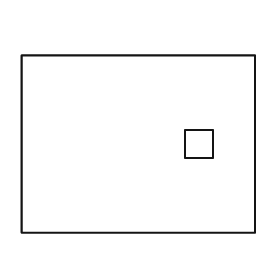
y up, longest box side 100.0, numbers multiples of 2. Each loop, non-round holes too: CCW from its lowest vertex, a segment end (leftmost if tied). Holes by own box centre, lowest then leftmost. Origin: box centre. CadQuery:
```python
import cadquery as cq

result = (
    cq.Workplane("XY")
    .moveTo(-50.0, -38.0)
    .lineTo(50.0, -38.0)
    .lineTo(50.0, 38.0)
    .lineTo(-50.0, 38.0)
    .close()
    .moveTo(20.0, -6.0)
    .lineTo(32.0, -6.0)
    .lineTo(32.0, 6.0)
    .lineTo(20.0, 6.0)
    .close()
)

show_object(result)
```